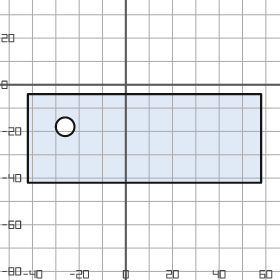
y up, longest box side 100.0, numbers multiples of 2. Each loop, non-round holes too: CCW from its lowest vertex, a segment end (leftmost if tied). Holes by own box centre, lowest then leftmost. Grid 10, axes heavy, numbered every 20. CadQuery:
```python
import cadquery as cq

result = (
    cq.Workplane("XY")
    .moveTo(-42.0, -42.0)
    .lineTo(58.0, -42.0)
    .lineTo(58.0, -4.0)
    .lineTo(-42.0, -4.0)
    .close()
    .moveTo(-26.0, -18.0)
    .circle(4.0)
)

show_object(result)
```